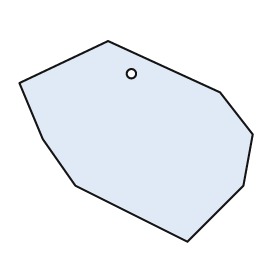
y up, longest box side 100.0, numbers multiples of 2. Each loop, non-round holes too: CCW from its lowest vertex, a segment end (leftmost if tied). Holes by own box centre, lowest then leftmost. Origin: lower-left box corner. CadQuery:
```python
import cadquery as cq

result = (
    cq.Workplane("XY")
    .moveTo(72.0, 0.0)
    .lineTo(96.0, 24.0)
    .lineTo(100.0, 46.0)
    .lineTo(86.0, 64.0)
    .lineTo(38.0, 86.0)
    .lineTo(0.0, 68.0)
    .lineTo(10.0, 44.0)
    .lineTo(24.0, 24.0)
    .close()
    .moveTo(48.0, 72.0)
    .circle(2.0)
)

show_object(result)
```